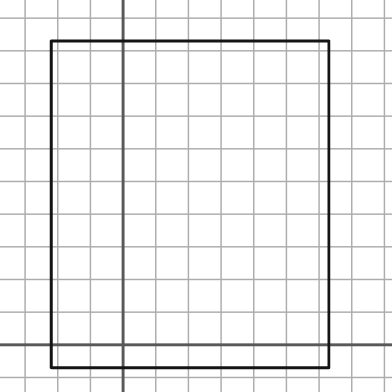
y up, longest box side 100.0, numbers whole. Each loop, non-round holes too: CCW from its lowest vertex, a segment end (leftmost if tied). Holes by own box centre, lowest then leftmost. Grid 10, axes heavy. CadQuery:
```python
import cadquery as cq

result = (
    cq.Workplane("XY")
    .moveTo(-22.0, -7.0)
    .lineTo(63.0, -7.0)
    .lineTo(63.0, 93.0)
    .lineTo(-22.0, 93.0)
    .close()
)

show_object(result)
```